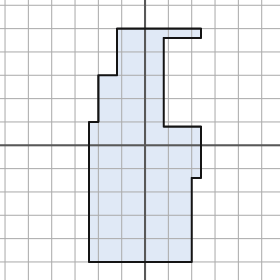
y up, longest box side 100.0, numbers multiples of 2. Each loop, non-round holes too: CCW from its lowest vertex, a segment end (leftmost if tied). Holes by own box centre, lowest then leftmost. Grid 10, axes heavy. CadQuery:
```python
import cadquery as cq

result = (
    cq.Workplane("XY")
    .moveTo(-24.0, -50.0)
    .lineTo(20.0, -50.0)
    .lineTo(20.0, -14.0)
    .lineTo(24.0, -14.0)
    .lineTo(24.0, 8.0)
    .lineTo(8.0, 8.0)
    .lineTo(8.0, 46.0)
    .lineTo(24.0, 46.0)
    .lineTo(24.0, 50.0)
    .lineTo(-12.0, 50.0)
    .lineTo(-12.0, 30.0)
    .lineTo(-20.0, 30.0)
    .lineTo(-20.0, 10.0)
    .lineTo(-24.0, 10.0)
    .close()
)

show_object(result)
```